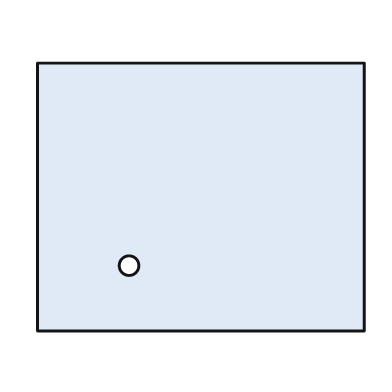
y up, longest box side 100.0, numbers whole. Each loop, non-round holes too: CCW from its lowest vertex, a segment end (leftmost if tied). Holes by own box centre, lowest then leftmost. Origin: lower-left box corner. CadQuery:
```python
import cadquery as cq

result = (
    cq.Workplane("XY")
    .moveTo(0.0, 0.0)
    .lineTo(100.0, 0.0)
    .lineTo(100.0, 82.0)
    .lineTo(0.0, 82.0)
    .close()
    .moveTo(28.0, 20.0)
    .circle(3.0)
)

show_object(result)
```